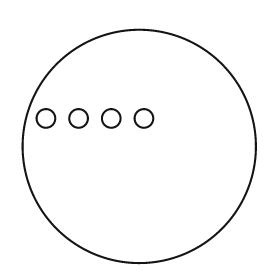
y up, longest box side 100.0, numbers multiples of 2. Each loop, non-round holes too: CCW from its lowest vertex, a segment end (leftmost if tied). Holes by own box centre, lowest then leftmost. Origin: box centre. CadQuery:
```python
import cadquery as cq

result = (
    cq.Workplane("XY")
    .moveTo(0.0, 0.0)
    .circle(50.0)
    .moveTo(-40.0, 12.0)
    .circle(4.0)
    .moveTo(-26.0, 12.0)
    .circle(4.0)
    .moveTo(-12.0, 12.0)
    .circle(4.0)
    .moveTo(2.0, 12.0)
    .circle(4.0)
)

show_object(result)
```